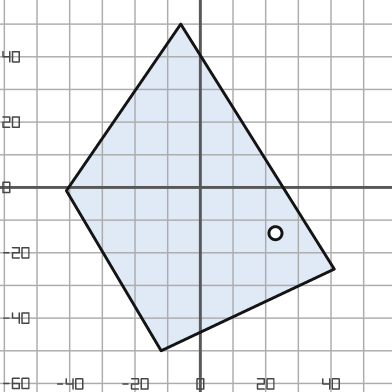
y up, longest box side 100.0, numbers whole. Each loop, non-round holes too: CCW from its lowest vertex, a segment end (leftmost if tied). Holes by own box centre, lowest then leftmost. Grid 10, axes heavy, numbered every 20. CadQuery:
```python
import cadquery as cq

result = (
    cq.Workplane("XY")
    .moveTo(-12.0, -50.0)
    .lineTo(41.0, -25.0)
    .lineTo(-6.0, 50.0)
    .lineTo(-41.0, -1.0)
    .close()
    .moveTo(23.0, -14.0)
    .circle(2.0)
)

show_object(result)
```